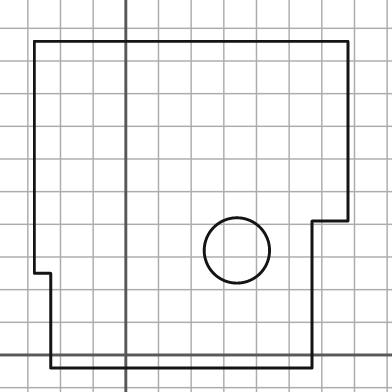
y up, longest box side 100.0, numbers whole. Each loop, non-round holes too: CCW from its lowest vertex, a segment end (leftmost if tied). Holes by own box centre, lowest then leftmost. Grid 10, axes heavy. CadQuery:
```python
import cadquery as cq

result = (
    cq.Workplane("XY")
    .moveTo(-23.0, -4.0)
    .lineTo(57.0, -4.0)
    .lineTo(57.0, 41.0)
    .lineTo(68.0, 41.0)
    .lineTo(68.0, 96.0)
    .lineTo(-28.0, 96.0)
    .lineTo(-28.0, 25.0)
    .lineTo(-23.0, 25.0)
    .close()
    .moveTo(34.0, 32.0)
    .circle(10.0)
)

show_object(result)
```